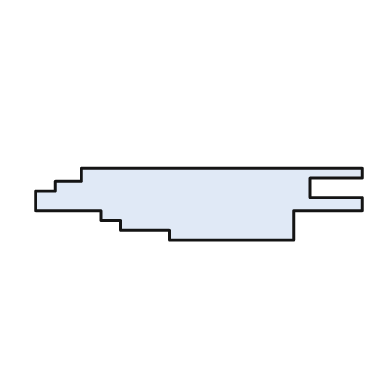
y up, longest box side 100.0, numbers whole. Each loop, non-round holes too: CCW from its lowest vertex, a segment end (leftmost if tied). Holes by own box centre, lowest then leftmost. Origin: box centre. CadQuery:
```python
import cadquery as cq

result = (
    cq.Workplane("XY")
    .moveTo(-9.0, -11.0)
    .lineTo(29.0, -11.0)
    .lineTo(29.0, -2.0)
    .lineTo(50.0, -2.0)
    .lineTo(50.0, 2.0)
    .lineTo(34.0, 2.0)
    .lineTo(34.0, 8.0)
    .lineTo(50.0, 8.0)
    .lineTo(50.0, 11.0)
    .lineTo(-36.0, 11.0)
    .lineTo(-36.0, 7.0)
    .lineTo(-44.0, 7.0)
    .lineTo(-44.0, 4.0)
    .lineTo(-50.0, 4.0)
    .lineTo(-50.0, -2.0)
    .lineTo(-30.0, -2.0)
    .lineTo(-30.0, -5.0)
    .lineTo(-24.0, -5.0)
    .lineTo(-24.0, -8.0)
    .lineTo(-9.0, -8.0)
    .close()
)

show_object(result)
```